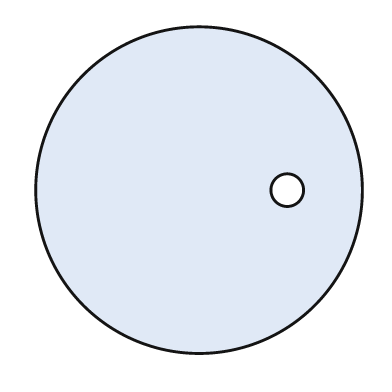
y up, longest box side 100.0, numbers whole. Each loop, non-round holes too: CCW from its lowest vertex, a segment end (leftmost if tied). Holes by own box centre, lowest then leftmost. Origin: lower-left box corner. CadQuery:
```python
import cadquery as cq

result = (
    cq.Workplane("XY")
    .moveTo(50.0, 50.0)
    .circle(50.0)
    .moveTo(77.0, 50.0)
    .circle(5.0)
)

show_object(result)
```